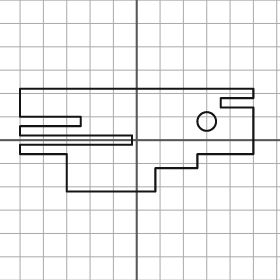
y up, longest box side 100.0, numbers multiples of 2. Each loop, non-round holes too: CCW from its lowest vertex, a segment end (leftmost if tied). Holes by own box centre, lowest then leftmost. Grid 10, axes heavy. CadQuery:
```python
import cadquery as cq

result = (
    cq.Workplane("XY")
    .moveTo(-30.0, -22.0)
    .lineTo(8.0, -22.0)
    .lineTo(8.0, -12.0)
    .lineTo(26.0, -12.0)
    .lineTo(26.0, -6.0)
    .lineTo(50.0, -6.0)
    .lineTo(50.0, 14.0)
    .lineTo(36.0, 14.0)
    .lineTo(36.0, 18.0)
    .lineTo(50.0, 18.0)
    .lineTo(50.0, 22.0)
    .lineTo(-50.0, 22.0)
    .lineTo(-50.0, 10.0)
    .lineTo(-24.0, 10.0)
    .lineTo(-24.0, 6.0)
    .lineTo(-50.0, 6.0)
    .lineTo(-50.0, 2.0)
    .lineTo(-2.0, 2.0)
    .lineTo(-2.0, -2.0)
    .lineTo(-50.0, -2.0)
    .lineTo(-50.0, -6.0)
    .lineTo(-30.0, -6.0)
    .close()
    .moveTo(30.0, 8.0)
    .circle(4.0)
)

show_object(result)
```